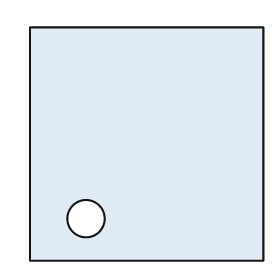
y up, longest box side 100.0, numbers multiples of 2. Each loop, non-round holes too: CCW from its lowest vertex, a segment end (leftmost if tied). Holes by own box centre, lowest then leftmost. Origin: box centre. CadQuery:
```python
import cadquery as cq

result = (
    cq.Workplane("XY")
    .moveTo(-50.0, -50.0)
    .lineTo(50.0, -50.0)
    .lineTo(50.0, 50.0)
    .lineTo(-50.0, 50.0)
    .close()
    .moveTo(-26.0, -32.0)
    .circle(8.0)
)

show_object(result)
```